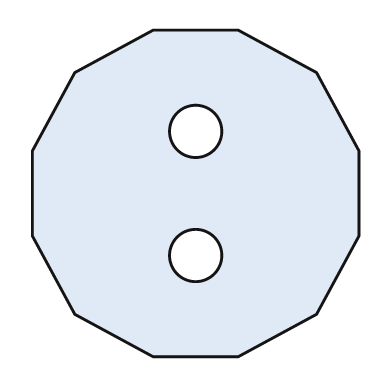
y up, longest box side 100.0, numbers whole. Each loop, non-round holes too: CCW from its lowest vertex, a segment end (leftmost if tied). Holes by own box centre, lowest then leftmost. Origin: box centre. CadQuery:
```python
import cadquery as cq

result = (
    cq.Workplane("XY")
    .moveTo(-13.0, -50.0)
    .lineTo(13.0, -50.0)
    .lineTo(37.0, -37.0)
    .lineTo(50.0, -13.0)
    .lineTo(50.0, 13.0)
    .lineTo(37.0, 37.0)
    .lineTo(13.0, 50.0)
    .lineTo(-13.0, 50.0)
    .lineTo(-37.0, 37.0)
    .lineTo(-50.0, 13.0)
    .lineTo(-50.0, -13.0)
    .lineTo(-37.0, -37.0)
    .close()
    .moveTo(0.0, -19.0)
    .circle(8.0)
    .moveTo(0.0, 19.0)
    .circle(8.0)
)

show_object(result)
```